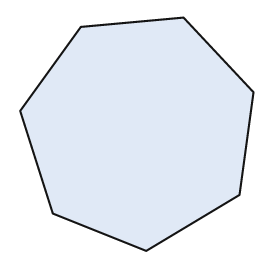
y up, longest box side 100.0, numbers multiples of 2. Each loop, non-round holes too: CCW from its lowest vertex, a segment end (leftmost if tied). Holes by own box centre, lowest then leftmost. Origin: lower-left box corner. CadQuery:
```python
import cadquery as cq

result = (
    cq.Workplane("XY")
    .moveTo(54.0, 0.0)
    .lineTo(94.0, 24.0)
    .lineTo(100.0, 68.0)
    .lineTo(70.0, 100.0)
    .lineTo(26.0, 96.0)
    .lineTo(0.0, 60.0)
    .lineTo(14.0, 16.0)
    .close()
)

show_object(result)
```